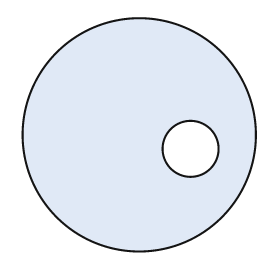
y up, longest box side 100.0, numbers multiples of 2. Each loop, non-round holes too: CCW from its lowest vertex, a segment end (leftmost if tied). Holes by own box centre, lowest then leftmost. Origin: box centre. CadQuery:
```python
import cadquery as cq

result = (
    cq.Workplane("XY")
    .moveTo(0.0, 0.0)
    .circle(50.0)
    .moveTo(22.0, -6.0)
    .circle(12.0)
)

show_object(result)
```